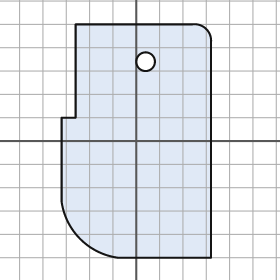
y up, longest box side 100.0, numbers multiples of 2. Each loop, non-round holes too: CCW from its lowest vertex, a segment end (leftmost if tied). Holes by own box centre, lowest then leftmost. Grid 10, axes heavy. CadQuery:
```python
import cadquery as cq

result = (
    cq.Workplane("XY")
    .moveTo(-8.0, -50.0)
    .lineTo(32.0, -50.0)
    .lineTo(32.0, 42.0)
    .threePointArc((30.0, 48.0), (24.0, 50.0))
    .lineTo(-26.0, 50.0)
    .lineTo(-26.0, 10.0)
    .lineTo(-32.0, 10.0)
    .lineTo(-32.0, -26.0)
    .threePointArc((-24.0, -42.0), (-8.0, -50.0))
    .close()
    .moveTo(4.0, 34.0)
    .circle(4.0)
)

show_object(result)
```